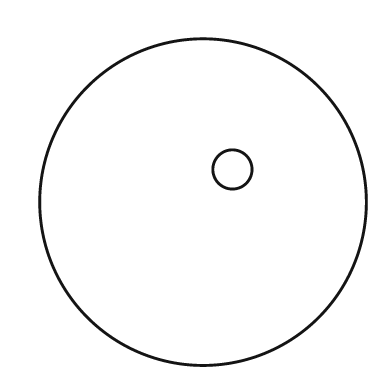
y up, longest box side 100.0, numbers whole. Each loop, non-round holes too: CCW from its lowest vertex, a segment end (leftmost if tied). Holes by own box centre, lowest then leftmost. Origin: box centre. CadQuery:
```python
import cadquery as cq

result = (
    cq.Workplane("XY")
    .moveTo(0.0, 0.0)
    .circle(50.0)
    .moveTo(9.0, 10.0)
    .circle(6.0)
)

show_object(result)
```